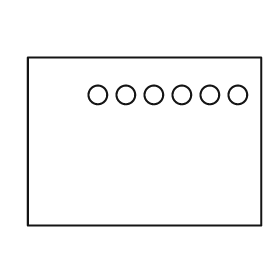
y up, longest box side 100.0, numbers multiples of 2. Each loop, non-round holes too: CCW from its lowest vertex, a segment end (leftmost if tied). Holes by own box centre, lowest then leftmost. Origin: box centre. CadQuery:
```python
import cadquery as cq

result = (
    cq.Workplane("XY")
    .moveTo(-50.0, -36.0)
    .lineTo(50.0, -36.0)
    .lineTo(50.0, 36.0)
    .lineTo(-50.0, 36.0)
    .close()
    .moveTo(-20.0, 20.0)
    .circle(4.0)
    .moveTo(-8.0, 20.0)
    .circle(4.0)
    .moveTo(4.0, 20.0)
    .circle(4.0)
    .moveTo(16.0, 20.0)
    .circle(4.0)
    .moveTo(28.0, 20.0)
    .circle(4.0)
    .moveTo(40.0, 20.0)
    .circle(4.0)
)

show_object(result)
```